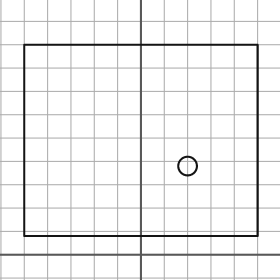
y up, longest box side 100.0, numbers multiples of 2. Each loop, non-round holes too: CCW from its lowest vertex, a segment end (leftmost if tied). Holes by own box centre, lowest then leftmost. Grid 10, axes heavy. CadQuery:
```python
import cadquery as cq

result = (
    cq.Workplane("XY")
    .moveTo(-50.0, 8.0)
    .lineTo(50.0, 8.0)
    .lineTo(50.0, 90.0)
    .lineTo(-50.0, 90.0)
    .close()
    .moveTo(20.0, 38.0)
    .circle(4.0)
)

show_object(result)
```